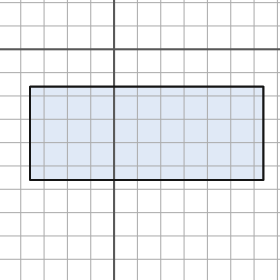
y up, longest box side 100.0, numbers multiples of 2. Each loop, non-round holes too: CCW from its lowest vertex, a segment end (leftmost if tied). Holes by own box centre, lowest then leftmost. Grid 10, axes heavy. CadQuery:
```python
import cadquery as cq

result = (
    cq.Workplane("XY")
    .moveTo(-36.0, -56.0)
    .lineTo(64.0, -56.0)
    .lineTo(64.0, -16.0)
    .lineTo(-36.0, -16.0)
    .close()
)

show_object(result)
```